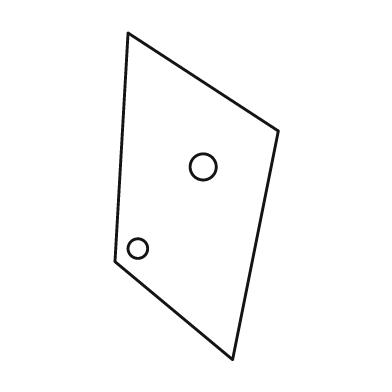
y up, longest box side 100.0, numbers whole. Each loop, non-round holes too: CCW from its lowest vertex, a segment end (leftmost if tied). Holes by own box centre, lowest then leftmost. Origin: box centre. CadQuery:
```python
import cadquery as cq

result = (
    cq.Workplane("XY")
    .moveTo(11.0, -50.0)
    .lineTo(25.0, 20.0)
    .lineTo(-21.0, 50.0)
    .lineTo(-25.0, -20.0)
    .close()
    .moveTo(-18.0, -16.0)
    .circle(3.0)
    .moveTo(2.0, 9.0)
    .circle(4.0)
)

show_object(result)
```